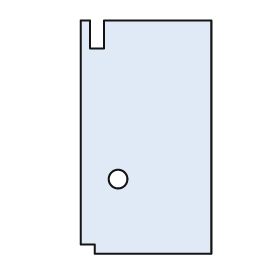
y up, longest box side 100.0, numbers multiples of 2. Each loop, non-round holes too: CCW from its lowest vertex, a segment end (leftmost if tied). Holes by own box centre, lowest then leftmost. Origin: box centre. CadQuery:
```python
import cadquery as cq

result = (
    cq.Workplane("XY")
    .moveTo(-22.0, -50.0)
    .lineTo(28.0, -50.0)
    .lineTo(28.0, 50.0)
    .lineTo(-18.0, 50.0)
    .lineTo(-18.0, 38.0)
    .lineTo(-24.0, 38.0)
    .lineTo(-24.0, 50.0)
    .lineTo(-28.0, 50.0)
    .lineTo(-28.0, -46.0)
    .lineTo(-22.0, -46.0)
    .close()
    .moveTo(-12.0, -18.0)
    .circle(4.0)
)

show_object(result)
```